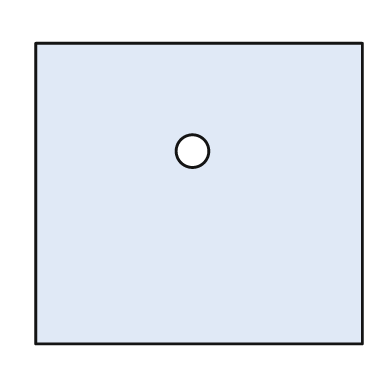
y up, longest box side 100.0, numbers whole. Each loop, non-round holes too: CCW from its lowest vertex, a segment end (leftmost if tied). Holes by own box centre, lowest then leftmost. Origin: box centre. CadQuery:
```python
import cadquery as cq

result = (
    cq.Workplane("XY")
    .moveTo(-50.0, -46.0)
    .lineTo(50.0, -46.0)
    .lineTo(50.0, 46.0)
    .lineTo(-50.0, 46.0)
    .close()
    .moveTo(-2.0, 13.0)
    .circle(5.0)
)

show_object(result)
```